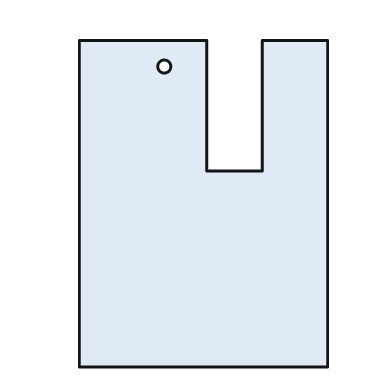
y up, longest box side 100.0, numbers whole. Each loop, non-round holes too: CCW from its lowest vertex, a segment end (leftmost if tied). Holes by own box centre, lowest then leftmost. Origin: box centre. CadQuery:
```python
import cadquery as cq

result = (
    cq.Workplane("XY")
    .moveTo(-38.0, -50.0)
    .lineTo(38.0, -50.0)
    .lineTo(38.0, 50.0)
    .lineTo(18.0, 50.0)
    .lineTo(18.0, 10.0)
    .lineTo(1.0, 10.0)
    .lineTo(1.0, 50.0)
    .lineTo(-38.0, 50.0)
    .close()
    .moveTo(-12.0, 42.0)
    .circle(2.0)
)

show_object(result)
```